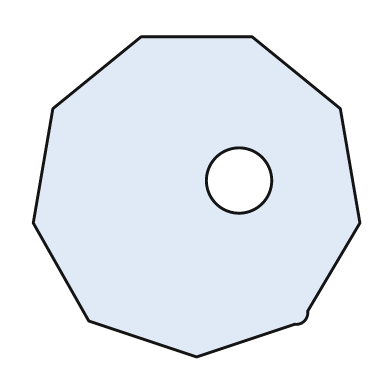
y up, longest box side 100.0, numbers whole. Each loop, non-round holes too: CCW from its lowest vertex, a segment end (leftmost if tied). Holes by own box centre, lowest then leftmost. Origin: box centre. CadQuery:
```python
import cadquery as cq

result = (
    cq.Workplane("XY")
    .moveTo(0.0, -49.0)
    .lineTo(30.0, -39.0)
    .threePointArc((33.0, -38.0), (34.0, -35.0))
    .lineTo(50.0, -8.0)
    .lineTo(44.0, 27.0)
    .lineTo(17.0, 49.0)
    .lineTo(-17.0, 49.0)
    .lineTo(-44.0, 27.0)
    .lineTo(-50.0, -8.0)
    .lineTo(-33.0, -38.0)
    .close()
    .moveTo(13.0, 5.0)
    .circle(10.0)
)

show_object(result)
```